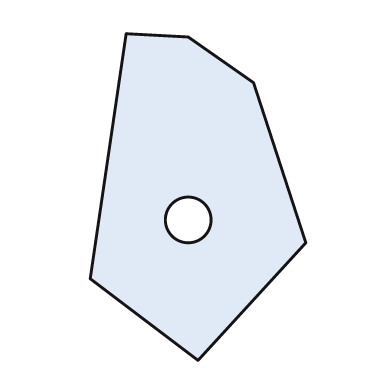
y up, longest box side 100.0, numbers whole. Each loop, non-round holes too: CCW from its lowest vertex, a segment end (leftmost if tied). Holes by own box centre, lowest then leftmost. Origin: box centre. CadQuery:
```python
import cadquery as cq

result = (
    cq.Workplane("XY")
    .moveTo(0.0, -50.0)
    .lineTo(33.0, -14.0)
    .lineTo(17.0, 35.0)
    .lineTo(-3.0, 49.0)
    .lineTo(-22.0, 50.0)
    .lineTo(-33.0, -25.0)
    .close()
    .moveTo(-3.0, -7.0)
    .circle(7.0)
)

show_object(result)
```